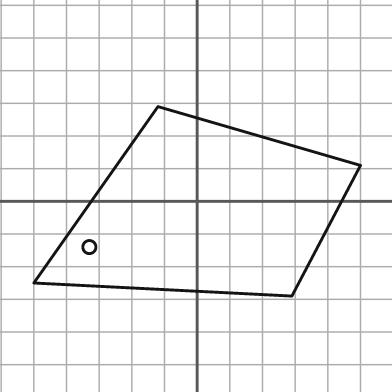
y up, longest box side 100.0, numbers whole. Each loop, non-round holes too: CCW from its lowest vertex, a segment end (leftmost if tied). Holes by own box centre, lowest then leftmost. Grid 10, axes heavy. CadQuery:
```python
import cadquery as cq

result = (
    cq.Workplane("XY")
    .moveTo(29.0, -29.0)
    .lineTo(50.0, 11.0)
    .lineTo(-12.0, 29.0)
    .lineTo(-50.0, -25.0)
    .close()
    .moveTo(-33.0, -14.0)
    .circle(2.0)
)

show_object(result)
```